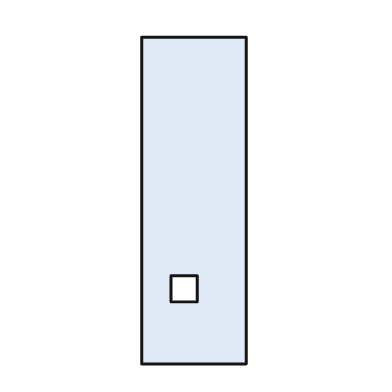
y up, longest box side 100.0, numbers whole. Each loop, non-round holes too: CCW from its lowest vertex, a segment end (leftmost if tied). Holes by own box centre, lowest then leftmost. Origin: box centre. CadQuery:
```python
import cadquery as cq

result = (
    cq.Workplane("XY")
    .moveTo(-16.0, -50.0)
    .lineTo(16.0, -50.0)
    .lineTo(16.0, 50.0)
    .lineTo(-16.0, 50.0)
    .close()
    .moveTo(-7.0, -31.0)
    .lineTo(1.0, -31.0)
    .lineTo(1.0, -23.0)
    .lineTo(-7.0, -23.0)
    .close()
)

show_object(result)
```